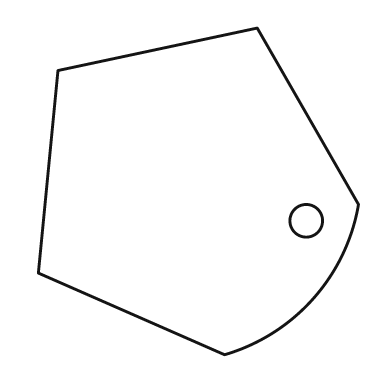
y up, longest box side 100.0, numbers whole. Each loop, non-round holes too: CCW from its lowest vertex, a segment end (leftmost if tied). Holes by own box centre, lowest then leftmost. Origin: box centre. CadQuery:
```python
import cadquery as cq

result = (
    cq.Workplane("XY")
    .moveTo(8.0, -50.0)
    .threePointArc((35.0, -33.0), (49.0, -4.0))
    .lineTo(18.0, 50.0)
    .lineTo(-43.0, 37.0)
    .lineTo(-49.0, -25.0)
    .close()
    .moveTo(33.0, -9.0)
    .circle(5.0)
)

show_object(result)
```